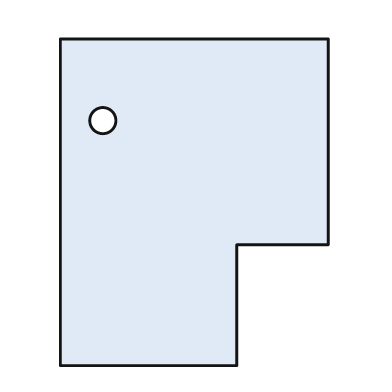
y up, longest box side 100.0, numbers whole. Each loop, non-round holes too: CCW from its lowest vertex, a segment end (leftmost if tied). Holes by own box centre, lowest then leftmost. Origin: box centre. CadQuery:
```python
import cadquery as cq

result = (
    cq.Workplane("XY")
    .moveTo(-41.0, -50.0)
    .lineTo(13.0, -50.0)
    .lineTo(13.0, -13.0)
    .lineTo(41.0, -13.0)
    .lineTo(41.0, 50.0)
    .lineTo(-41.0, 50.0)
    .close()
    .moveTo(-28.0, 25.0)
    .circle(4.0)
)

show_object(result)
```